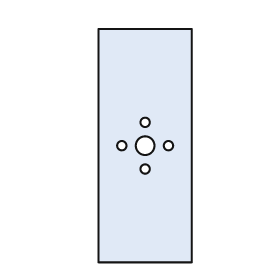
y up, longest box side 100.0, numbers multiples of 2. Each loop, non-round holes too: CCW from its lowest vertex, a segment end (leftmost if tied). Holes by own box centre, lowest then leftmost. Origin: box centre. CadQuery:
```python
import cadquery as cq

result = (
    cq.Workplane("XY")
    .moveTo(-20.0, -50.0)
    .lineTo(20.0, -50.0)
    .lineTo(20.0, 50.0)
    .lineTo(-20.0, 50.0)
    .close()
    .moveTo(0.0, -10.0)
    .circle(2.0)
    .moveTo(-10.0, 0.0)
    .circle(2.0)
    .moveTo(0.0, 0.0)
    .circle(4.0)
    .moveTo(10.0, 0.0)
    .circle(2.0)
    .moveTo(0.0, 10.0)
    .circle(2.0)
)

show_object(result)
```